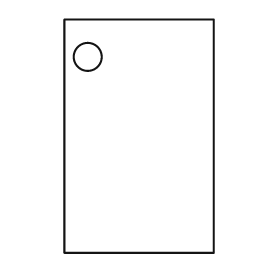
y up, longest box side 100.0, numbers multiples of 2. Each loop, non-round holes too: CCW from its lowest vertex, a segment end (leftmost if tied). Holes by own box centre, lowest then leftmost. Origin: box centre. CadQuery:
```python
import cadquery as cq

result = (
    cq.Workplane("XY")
    .moveTo(-32.0, -50.0)
    .lineTo(32.0, -50.0)
    .lineTo(32.0, 50.0)
    .lineTo(-32.0, 50.0)
    .close()
    .moveTo(-22.0, 34.0)
    .circle(6.0)
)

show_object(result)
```